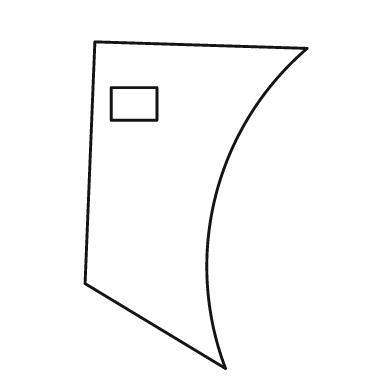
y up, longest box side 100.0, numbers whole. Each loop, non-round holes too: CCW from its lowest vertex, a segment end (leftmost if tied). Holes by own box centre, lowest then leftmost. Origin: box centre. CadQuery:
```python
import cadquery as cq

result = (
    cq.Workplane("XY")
    .moveTo(9.0, -50.0)
    .threePointArc((6.0, 3.0), (34.0, 48.0))
    .lineTo(-31.0, 50.0)
    .lineTo(-34.0, -24.0)
    .close()
    .moveTo(-26.0, 26.0)
    .lineTo(-12.0, 26.0)
    .lineTo(-12.0, 36.0)
    .lineTo(-26.0, 36.0)
    .close()
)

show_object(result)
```